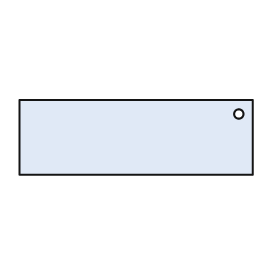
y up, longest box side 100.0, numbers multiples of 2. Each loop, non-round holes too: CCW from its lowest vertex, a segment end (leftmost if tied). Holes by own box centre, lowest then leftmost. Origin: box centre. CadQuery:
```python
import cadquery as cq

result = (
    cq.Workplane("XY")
    .moveTo(-50.0, -16.0)
    .lineTo(50.0, -16.0)
    .lineTo(50.0, 16.0)
    .lineTo(-50.0, 16.0)
    .close()
    .moveTo(44.0, 10.0)
    .circle(2.0)
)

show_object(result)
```